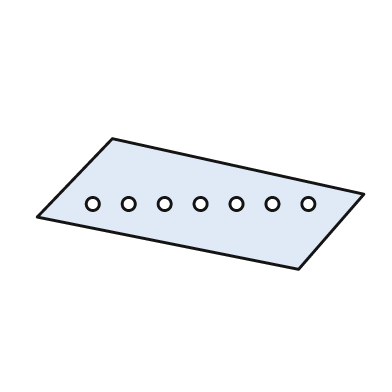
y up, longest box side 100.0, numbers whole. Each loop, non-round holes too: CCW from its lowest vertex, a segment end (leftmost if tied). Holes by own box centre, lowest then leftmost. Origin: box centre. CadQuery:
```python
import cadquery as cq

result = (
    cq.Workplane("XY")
    .moveTo(30.0, -20.0)
    .lineTo(50.0, 3.0)
    .lineTo(-27.0, 20.0)
    .lineTo(-50.0, -4.0)
    .close()
    .moveTo(-33.0, 0.0)
    .circle(2.0)
    .moveTo(-22.0, 0.0)
    .circle(2.0)
    .moveTo(-11.0, 0.0)
    .circle(2.0)
    .moveTo(0.0, 0.0)
    .circle(2.0)
    .moveTo(11.0, 0.0)
    .circle(2.0)
    .moveTo(22.0, 0.0)
    .circle(2.0)
    .moveTo(33.0, 0.0)
    .circle(2.0)
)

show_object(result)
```